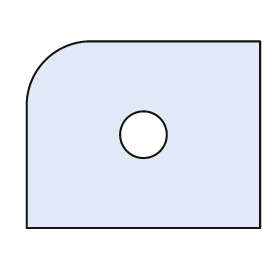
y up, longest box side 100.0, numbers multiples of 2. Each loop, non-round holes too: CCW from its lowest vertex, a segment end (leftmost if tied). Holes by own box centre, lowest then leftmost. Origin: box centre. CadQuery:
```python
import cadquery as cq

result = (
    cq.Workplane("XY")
    .moveTo(-50.0, -40.0)
    .lineTo(50.0, -40.0)
    .lineTo(50.0, 40.0)
    .lineTo(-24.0, 40.0)
    .threePointArc((-42.0, 32.0), (-50.0, 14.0))
    .close()
    .moveTo(0.0, 0.0)
    .circle(10.0)
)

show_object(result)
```